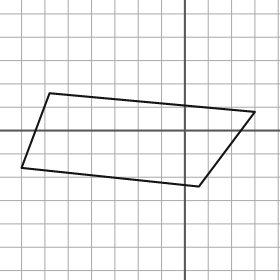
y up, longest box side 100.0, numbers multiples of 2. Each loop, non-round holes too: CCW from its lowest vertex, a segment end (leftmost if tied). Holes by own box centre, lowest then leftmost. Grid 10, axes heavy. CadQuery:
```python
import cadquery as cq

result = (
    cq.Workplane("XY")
    .moveTo(6.0, -24.0)
    .lineTo(30.0, 8.0)
    .lineTo(-58.0, 16.0)
    .lineTo(-70.0, -16.0)
    .close()
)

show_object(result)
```